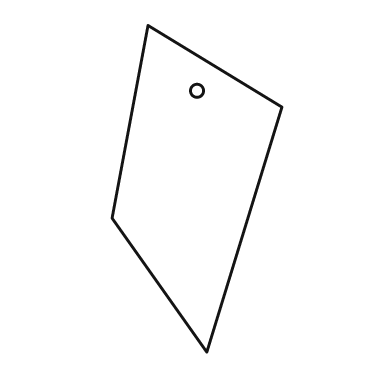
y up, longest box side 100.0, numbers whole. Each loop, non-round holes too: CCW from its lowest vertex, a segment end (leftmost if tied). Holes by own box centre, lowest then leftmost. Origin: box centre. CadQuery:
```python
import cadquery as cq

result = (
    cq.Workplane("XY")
    .moveTo(3.0, -50.0)
    .lineTo(26.0, 25.0)
    .lineTo(-15.0, 50.0)
    .lineTo(-26.0, -9.0)
    .close()
    .moveTo(0.0, 30.0)
    .circle(2.0)
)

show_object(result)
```